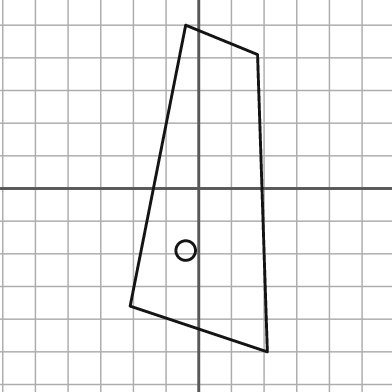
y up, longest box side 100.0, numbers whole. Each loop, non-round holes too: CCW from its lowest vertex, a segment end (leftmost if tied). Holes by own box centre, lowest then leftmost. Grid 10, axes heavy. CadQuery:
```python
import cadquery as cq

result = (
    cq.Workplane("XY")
    .moveTo(21.0, -50.0)
    .lineTo(18.0, 41.0)
    .lineTo(-4.0, 50.0)
    .lineTo(-21.0, -36.0)
    .close()
    .moveTo(-4.0, -19.0)
    .circle(3.0)
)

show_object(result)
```